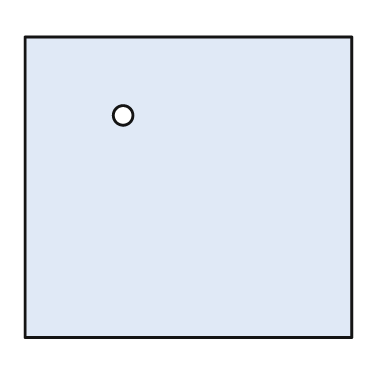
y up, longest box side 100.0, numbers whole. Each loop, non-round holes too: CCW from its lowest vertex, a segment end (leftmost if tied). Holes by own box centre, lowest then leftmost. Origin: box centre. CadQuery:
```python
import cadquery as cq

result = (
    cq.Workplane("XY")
    .moveTo(-50.0, -46.0)
    .lineTo(50.0, -46.0)
    .lineTo(50.0, 46.0)
    .lineTo(-50.0, 46.0)
    .close()
    .moveTo(-20.0, 22.0)
    .circle(3.0)
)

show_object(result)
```